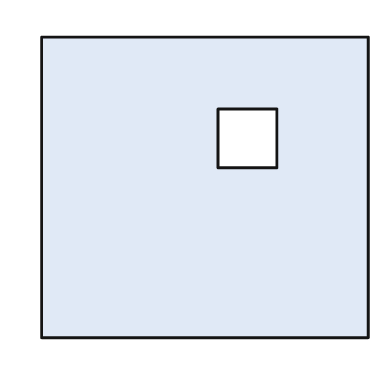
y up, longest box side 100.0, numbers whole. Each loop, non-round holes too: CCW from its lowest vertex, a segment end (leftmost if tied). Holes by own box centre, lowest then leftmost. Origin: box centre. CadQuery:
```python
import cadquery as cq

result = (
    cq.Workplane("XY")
    .moveTo(-50.0, -46.0)
    .lineTo(50.0, -46.0)
    .lineTo(50.0, 46.0)
    .lineTo(-50.0, 46.0)
    .close()
    .moveTo(4.0, 6.0)
    .lineTo(22.0, 6.0)
    .lineTo(22.0, 24.0)
    .lineTo(4.0, 24.0)
    .close()
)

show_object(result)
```